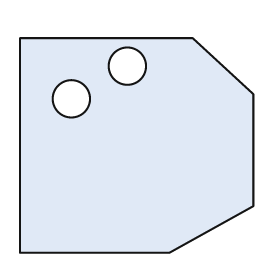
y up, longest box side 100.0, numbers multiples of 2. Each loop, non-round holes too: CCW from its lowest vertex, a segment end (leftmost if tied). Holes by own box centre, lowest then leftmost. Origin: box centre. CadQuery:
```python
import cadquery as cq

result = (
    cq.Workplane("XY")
    .moveTo(-50.0, -46.0)
    .lineTo(14.0, -46.0)
    .lineTo(50.0, -26.0)
    .lineTo(50.0, 22.0)
    .lineTo(24.0, 46.0)
    .lineTo(-50.0, 46.0)
    .close()
    .moveTo(-28.0, 20.0)
    .circle(8.0)
    .moveTo(-4.0, 34.0)
    .circle(8.0)
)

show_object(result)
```